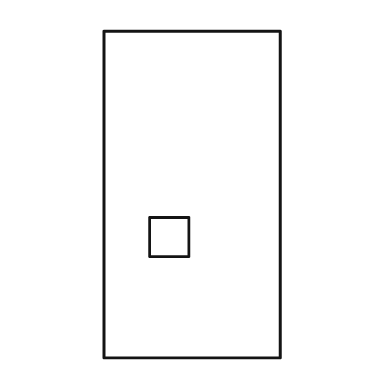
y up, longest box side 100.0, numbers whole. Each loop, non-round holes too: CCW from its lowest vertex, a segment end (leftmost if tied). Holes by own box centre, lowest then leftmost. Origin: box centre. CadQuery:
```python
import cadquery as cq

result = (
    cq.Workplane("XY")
    .moveTo(-27.0, -50.0)
    .lineTo(27.0, -50.0)
    .lineTo(27.0, 50.0)
    .lineTo(-27.0, 50.0)
    .close()
    .moveTo(-13.0, -19.0)
    .lineTo(-1.0, -19.0)
    .lineTo(-1.0, -7.0)
    .lineTo(-13.0, -7.0)
    .close()
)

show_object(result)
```